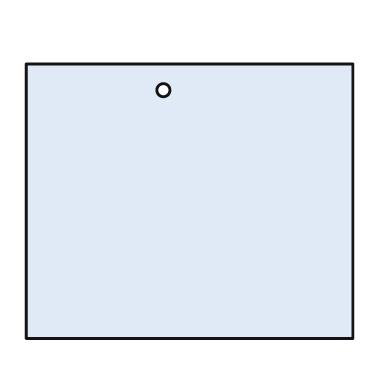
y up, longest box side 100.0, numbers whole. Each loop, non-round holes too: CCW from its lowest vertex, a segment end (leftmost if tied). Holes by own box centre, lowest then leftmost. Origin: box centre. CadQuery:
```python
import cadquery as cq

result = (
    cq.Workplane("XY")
    .moveTo(-50.0, -42.0)
    .lineTo(50.0, -42.0)
    .lineTo(50.0, 42.0)
    .lineTo(-50.0, 42.0)
    .close()
    .moveTo(-8.0, 34.0)
    .circle(2.0)
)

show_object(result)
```